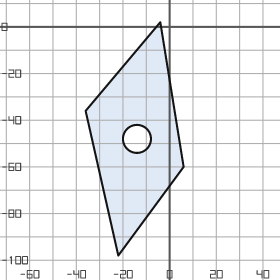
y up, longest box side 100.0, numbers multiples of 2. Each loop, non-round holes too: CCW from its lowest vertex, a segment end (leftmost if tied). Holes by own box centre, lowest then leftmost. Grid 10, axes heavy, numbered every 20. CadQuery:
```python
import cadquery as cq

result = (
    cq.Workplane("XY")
    .moveTo(-22.0, -98.0)
    .lineTo(6.0, -60.0)
    .lineTo(-4.0, 2.0)
    .lineTo(-36.0, -36.0)
    .close()
    .moveTo(-14.0, -48.0)
    .circle(6.0)
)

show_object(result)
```